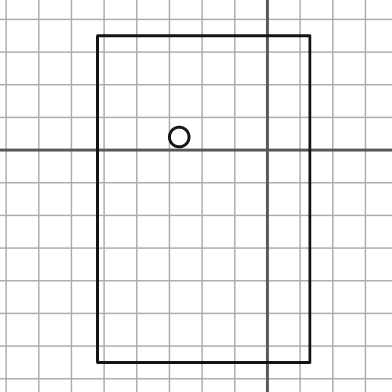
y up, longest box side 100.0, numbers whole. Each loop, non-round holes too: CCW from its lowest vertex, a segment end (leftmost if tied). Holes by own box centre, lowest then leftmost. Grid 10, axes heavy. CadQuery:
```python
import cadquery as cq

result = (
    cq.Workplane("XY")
    .moveTo(-52.0, -65.0)
    .lineTo(13.0, -65.0)
    .lineTo(13.0, 35.0)
    .lineTo(-52.0, 35.0)
    .close()
    .moveTo(-27.0, 4.0)
    .circle(3.0)
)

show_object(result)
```